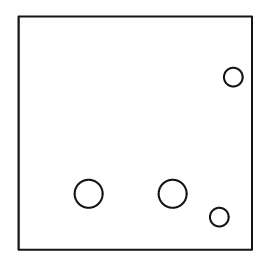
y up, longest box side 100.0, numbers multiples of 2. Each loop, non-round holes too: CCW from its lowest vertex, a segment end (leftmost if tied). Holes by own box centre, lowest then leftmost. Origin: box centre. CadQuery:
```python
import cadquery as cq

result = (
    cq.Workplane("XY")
    .moveTo(-50.0, -50.0)
    .lineTo(50.0, -50.0)
    .lineTo(50.0, 50.0)
    .lineTo(-50.0, 50.0)
    .close()
    .moveTo(36.0, -36.0)
    .circle(4.0)
    .moveTo(-20.0, -26.0)
    .circle(6.0)
    .moveTo(16.0, -26.0)
    .circle(6.0)
    .moveTo(42.0, 24.0)
    .circle(4.0)
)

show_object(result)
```